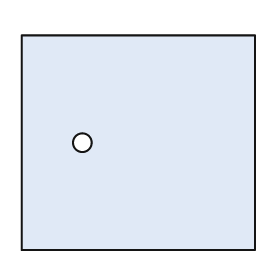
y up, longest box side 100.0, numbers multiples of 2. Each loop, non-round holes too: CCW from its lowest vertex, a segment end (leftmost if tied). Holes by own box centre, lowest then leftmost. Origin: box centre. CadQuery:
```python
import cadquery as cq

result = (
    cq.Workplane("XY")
    .moveTo(-50.0, -46.0)
    .lineTo(50.0, -46.0)
    .lineTo(50.0, 46.0)
    .lineTo(-50.0, 46.0)
    .close()
    .moveTo(-24.0, 0.0)
    .circle(4.0)
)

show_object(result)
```